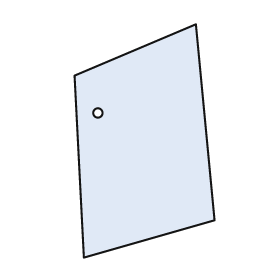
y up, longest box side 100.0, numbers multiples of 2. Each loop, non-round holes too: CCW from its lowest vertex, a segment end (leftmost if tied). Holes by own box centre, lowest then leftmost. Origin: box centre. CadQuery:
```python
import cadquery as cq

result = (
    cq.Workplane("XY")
    .moveTo(-26.0, -50.0)
    .lineTo(30.0, -34.0)
    .lineTo(22.0, 50.0)
    .lineTo(-30.0, 28.0)
    .close()
    .moveTo(-20.0, 12.0)
    .circle(2.0)
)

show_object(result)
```